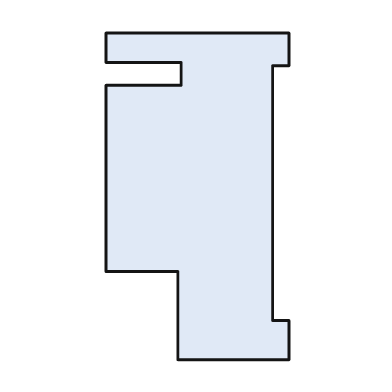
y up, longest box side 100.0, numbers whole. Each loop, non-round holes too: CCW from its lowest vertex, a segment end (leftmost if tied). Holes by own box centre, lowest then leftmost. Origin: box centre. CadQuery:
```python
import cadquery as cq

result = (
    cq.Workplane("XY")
    .moveTo(-6.0, -50.0)
    .lineTo(28.0, -50.0)
    .lineTo(28.0, -38.0)
    .lineTo(23.0, -38.0)
    .lineTo(23.0, 40.0)
    .lineTo(28.0, 40.0)
    .lineTo(28.0, 50.0)
    .lineTo(-28.0, 50.0)
    .lineTo(-28.0, 41.0)
    .lineTo(-5.0, 41.0)
    .lineTo(-5.0, 34.0)
    .lineTo(-28.0, 34.0)
    .lineTo(-28.0, -23.0)
    .lineTo(-6.0, -23.0)
    .close()
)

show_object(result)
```